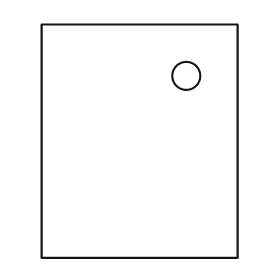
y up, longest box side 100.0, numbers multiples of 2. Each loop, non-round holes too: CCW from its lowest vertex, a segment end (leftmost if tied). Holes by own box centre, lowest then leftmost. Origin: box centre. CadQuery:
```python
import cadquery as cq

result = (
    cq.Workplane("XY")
    .moveTo(-42.0, -50.0)
    .lineTo(42.0, -50.0)
    .lineTo(42.0, 50.0)
    .lineTo(-42.0, 50.0)
    .close()
    .moveTo(20.0, 28.0)
    .circle(6.0)
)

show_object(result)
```